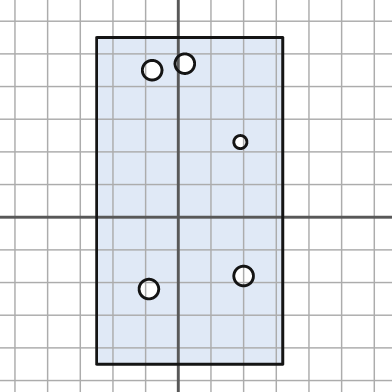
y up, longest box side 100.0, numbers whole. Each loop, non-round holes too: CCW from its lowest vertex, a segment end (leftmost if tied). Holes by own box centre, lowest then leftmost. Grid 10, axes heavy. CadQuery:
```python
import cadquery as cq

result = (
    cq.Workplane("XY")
    .moveTo(-25.0, -45.0)
    .lineTo(32.0, -45.0)
    .lineTo(32.0, 55.0)
    .lineTo(-25.0, 55.0)
    .close()
    .moveTo(-9.0, -22.0)
    .circle(3.0)
    .moveTo(20.0, -18.0)
    .circle(3.0)
    .moveTo(19.0, 23.0)
    .circle(2.0)
    .moveTo(-8.0, 45.0)
    .circle(3.0)
    .moveTo(2.0, 47.0)
    .circle(3.0)
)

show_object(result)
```